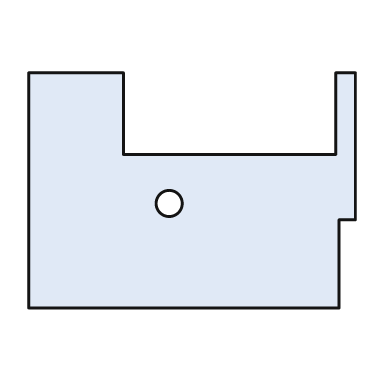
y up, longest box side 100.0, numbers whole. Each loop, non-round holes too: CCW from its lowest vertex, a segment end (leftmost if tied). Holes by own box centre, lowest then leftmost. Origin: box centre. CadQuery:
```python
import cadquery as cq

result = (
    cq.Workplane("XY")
    .moveTo(-50.0, -36.0)
    .lineTo(45.0, -36.0)
    .lineTo(45.0, -9.0)
    .lineTo(50.0, -9.0)
    .lineTo(50.0, 36.0)
    .lineTo(44.0, 36.0)
    .lineTo(44.0, 11.0)
    .lineTo(-21.0, 11.0)
    .lineTo(-21.0, 36.0)
    .lineTo(-50.0, 36.0)
    .close()
    .moveTo(-7.0, -4.0)
    .circle(4.0)
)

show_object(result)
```